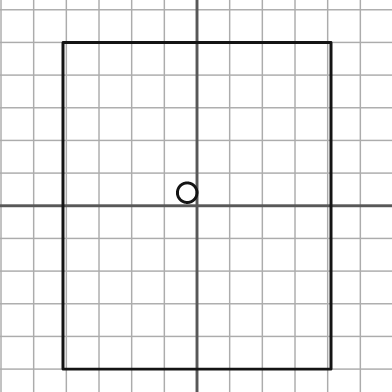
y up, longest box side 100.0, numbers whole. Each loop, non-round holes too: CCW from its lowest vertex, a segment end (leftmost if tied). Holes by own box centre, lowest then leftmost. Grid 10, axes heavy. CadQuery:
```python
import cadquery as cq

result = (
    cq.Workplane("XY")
    .moveTo(-41.0, -50.0)
    .lineTo(41.0, -50.0)
    .lineTo(41.0, 50.0)
    .lineTo(-41.0, 50.0)
    .close()
    .moveTo(-3.0, 4.0)
    .circle(3.0)
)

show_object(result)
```